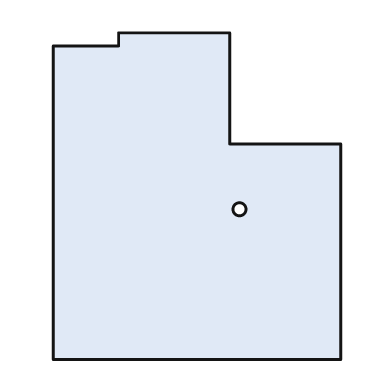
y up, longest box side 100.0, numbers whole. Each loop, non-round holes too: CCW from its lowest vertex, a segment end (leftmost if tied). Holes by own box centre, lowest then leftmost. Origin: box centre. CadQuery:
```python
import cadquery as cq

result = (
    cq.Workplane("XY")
    .moveTo(-44.0, -50.0)
    .lineTo(44.0, -50.0)
    .lineTo(44.0, 16.0)
    .lineTo(10.0, 16.0)
    .lineTo(10.0, 50.0)
    .lineTo(-24.0, 50.0)
    .lineTo(-24.0, 46.0)
    .lineTo(-44.0, 46.0)
    .close()
    .moveTo(13.0, -4.0)
    .circle(2.0)
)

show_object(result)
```